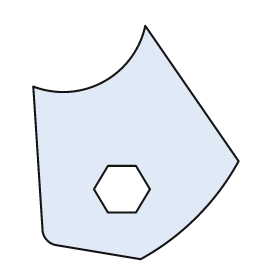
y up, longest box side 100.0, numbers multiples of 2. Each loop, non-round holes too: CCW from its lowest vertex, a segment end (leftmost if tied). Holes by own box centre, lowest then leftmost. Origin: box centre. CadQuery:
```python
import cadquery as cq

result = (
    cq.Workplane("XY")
    .moveTo(2.0, -50.0)
    .threePointArc((26.0, -32.0), (44.0, -8.0))
    .lineTo(4.0, 50.0)
    .threePointArc((-14.0, 26.0), (-44.0, 24.0))
    .lineTo(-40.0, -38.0)
    .threePointArc((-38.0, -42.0), (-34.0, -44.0))
    .close()
    .moveTo(-12.0, -30.0)
    .lineTo(0.0, -30.0)
    .lineTo(6.0, -20.0)
    .lineTo(0.0, -10.0)
    .lineTo(-12.0, -10.0)
    .lineTo(-18.0, -20.0)
    .close()
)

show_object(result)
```